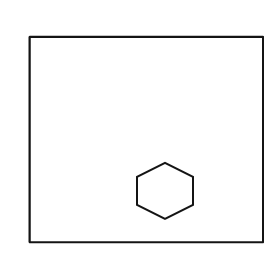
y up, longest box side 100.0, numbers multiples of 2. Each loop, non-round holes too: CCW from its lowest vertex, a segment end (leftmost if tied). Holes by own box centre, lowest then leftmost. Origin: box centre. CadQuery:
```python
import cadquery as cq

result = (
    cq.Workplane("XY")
    .moveTo(-50.0, -44.0)
    .lineTo(50.0, -44.0)
    .lineTo(50.0, 44.0)
    .lineTo(-50.0, 44.0)
    .close()
    .moveTo(8.0, -34.0)
    .lineTo(20.0, -28.0)
    .lineTo(20.0, -16.0)
    .lineTo(8.0, -10.0)
    .lineTo(-4.0, -16.0)
    .lineTo(-4.0, -28.0)
    .close()
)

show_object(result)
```